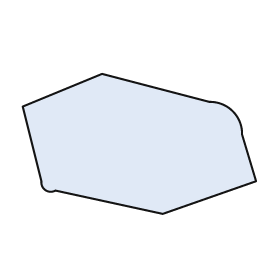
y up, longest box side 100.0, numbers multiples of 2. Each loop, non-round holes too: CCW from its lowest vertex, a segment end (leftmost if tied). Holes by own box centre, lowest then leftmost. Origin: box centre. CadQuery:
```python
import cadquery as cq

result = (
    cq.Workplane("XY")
    .moveTo(10.0, -30.0)
    .lineTo(50.0, -16.0)
    .lineTo(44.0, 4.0)
    .threePointArc((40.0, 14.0), (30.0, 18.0))
    .lineTo(-16.0, 30.0)
    .lineTo(-50.0, 16.0)
    .lineTo(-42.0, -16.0)
    .threePointArc((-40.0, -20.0), (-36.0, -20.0))
    .close()
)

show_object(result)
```